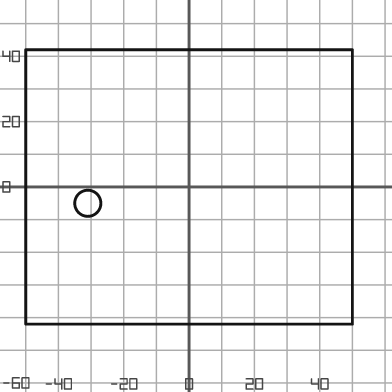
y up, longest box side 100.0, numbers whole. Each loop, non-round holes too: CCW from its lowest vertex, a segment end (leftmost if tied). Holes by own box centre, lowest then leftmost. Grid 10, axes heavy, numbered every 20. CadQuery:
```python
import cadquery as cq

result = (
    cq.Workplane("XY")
    .moveTo(-50.0, -42.0)
    .lineTo(50.0, -42.0)
    .lineTo(50.0, 42.0)
    .lineTo(-50.0, 42.0)
    .close()
    .moveTo(-31.0, -5.0)
    .circle(4.0)
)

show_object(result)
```